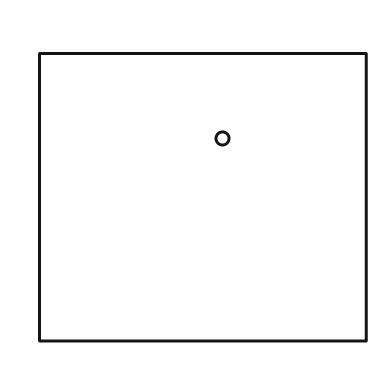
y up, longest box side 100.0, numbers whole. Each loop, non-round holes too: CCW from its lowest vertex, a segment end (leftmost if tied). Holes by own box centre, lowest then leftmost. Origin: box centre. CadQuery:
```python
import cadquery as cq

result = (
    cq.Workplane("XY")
    .moveTo(-50.0, -44.0)
    .lineTo(50.0, -44.0)
    .lineTo(50.0, 44.0)
    .lineTo(-50.0, 44.0)
    .close()
    .moveTo(6.0, 18.0)
    .circle(2.0)
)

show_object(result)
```